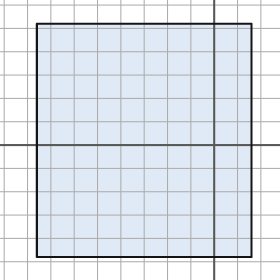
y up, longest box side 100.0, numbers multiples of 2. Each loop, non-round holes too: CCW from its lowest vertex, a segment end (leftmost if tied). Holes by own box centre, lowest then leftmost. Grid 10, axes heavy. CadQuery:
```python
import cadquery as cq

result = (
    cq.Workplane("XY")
    .moveTo(-76.0, -48.0)
    .lineTo(16.0, -48.0)
    .lineTo(16.0, 52.0)
    .lineTo(-76.0, 52.0)
    .close()
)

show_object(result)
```